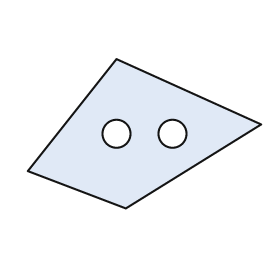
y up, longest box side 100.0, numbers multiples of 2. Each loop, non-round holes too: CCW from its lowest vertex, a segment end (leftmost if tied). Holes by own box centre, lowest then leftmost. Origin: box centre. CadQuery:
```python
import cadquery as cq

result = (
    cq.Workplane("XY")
    .moveTo(-8.0, -32.0)
    .lineTo(50.0, 4.0)
    .lineTo(-12.0, 32.0)
    .lineTo(-50.0, -16.0)
    .close()
    .moveTo(-12.0, 0.0)
    .circle(6.0)
    .moveTo(12.0, 0.0)
    .circle(6.0)
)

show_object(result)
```